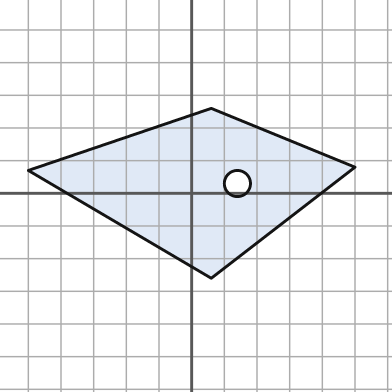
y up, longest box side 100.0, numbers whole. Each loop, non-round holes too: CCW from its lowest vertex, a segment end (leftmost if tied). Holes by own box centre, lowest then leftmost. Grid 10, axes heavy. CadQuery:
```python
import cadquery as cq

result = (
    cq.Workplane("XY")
    .moveTo(6.0, -26.0)
    .lineTo(50.0, 8.0)
    .lineTo(6.0, 26.0)
    .lineTo(-50.0, 7.0)
    .close()
    .moveTo(14.0, 3.0)
    .circle(4.0)
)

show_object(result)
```